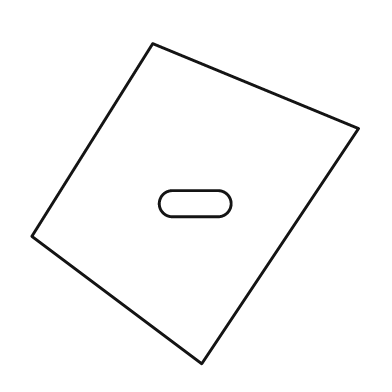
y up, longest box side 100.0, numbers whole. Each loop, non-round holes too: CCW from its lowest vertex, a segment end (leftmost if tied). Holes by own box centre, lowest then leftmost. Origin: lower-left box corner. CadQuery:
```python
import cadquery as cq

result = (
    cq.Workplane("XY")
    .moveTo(52.0, 0.0)
    .lineTo(100.0, 72.0)
    .lineTo(37.0, 98.0)
    .lineTo(0.0, 39.0)
    .close()
    .moveTo(43.0, 45.0)
    .lineTo(57.0, 45.0)
    .threePointArc((61.0, 49.0), (57.0, 53.0))
    .lineTo(43.0, 53.0)
    .threePointArc((39.0, 49.0), (43.0, 45.0))
    .close()
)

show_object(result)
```